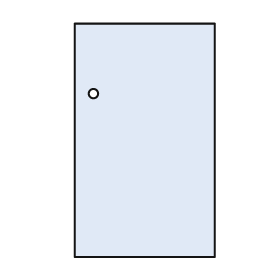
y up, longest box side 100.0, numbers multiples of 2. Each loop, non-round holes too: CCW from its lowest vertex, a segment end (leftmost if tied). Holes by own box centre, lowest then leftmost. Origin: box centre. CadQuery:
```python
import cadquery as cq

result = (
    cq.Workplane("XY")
    .moveTo(-30.0, -50.0)
    .lineTo(30.0, -50.0)
    .lineTo(30.0, 50.0)
    .lineTo(-30.0, 50.0)
    .close()
    .moveTo(-22.0, 20.0)
    .circle(2.0)
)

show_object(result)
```